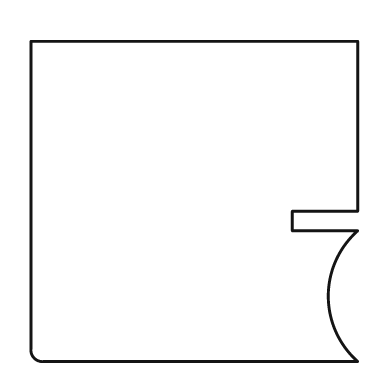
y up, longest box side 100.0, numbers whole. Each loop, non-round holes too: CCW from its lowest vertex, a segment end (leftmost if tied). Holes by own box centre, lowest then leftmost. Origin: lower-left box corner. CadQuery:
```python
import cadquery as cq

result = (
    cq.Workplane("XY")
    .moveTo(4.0, 0.0)
    .lineTo(100.0, 0.0)
    .threePointArc((91.0, 20.0), (100.0, 40.0))
    .lineTo(80.0, 40.0)
    .lineTo(80.0, 46.0)
    .lineTo(100.0, 46.0)
    .lineTo(100.0, 98.0)
    .lineTo(0.0, 98.0)
    .lineTo(0.0, 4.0)
    .threePointArc((1.0, 1.0), (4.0, 0.0))
    .close()
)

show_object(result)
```